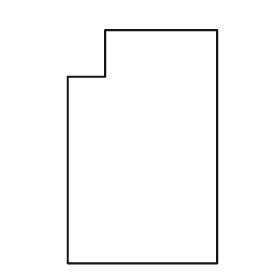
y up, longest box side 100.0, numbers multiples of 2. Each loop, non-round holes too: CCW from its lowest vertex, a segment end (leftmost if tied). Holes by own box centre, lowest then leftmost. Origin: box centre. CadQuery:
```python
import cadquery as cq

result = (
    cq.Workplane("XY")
    .moveTo(-32.0, -50.0)
    .lineTo(32.0, -50.0)
    .lineTo(32.0, 50.0)
    .lineTo(-16.0, 50.0)
    .lineTo(-16.0, 30.0)
    .lineTo(-32.0, 30.0)
    .close()
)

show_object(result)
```